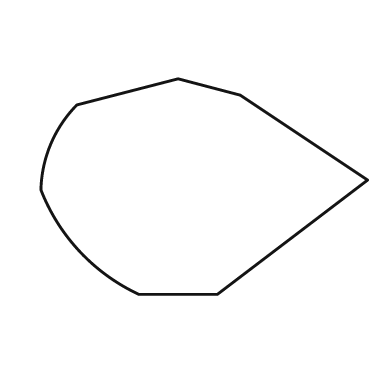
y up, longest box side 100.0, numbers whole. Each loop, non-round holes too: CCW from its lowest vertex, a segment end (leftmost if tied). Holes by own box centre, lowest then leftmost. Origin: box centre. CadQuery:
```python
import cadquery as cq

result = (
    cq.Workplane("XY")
    .moveTo(-20.0, -33.0)
    .lineTo(4.0, -33.0)
    .lineTo(50.0, 2.0)
    .lineTo(11.0, 28.0)
    .lineTo(-8.0, 33.0)
    .lineTo(-39.0, 25.0)
    .threePointArc((-47.0, 13.0), (-50.0, -1.0))
    .threePointArc((-38.0, -20.0), (-20.0, -33.0))
    .close()
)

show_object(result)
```